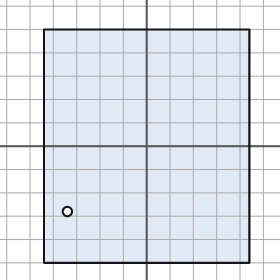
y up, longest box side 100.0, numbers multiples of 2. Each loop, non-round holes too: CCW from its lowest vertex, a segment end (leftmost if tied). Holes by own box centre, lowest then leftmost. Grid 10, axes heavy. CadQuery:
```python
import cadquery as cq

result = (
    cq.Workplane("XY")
    .moveTo(-44.0, -50.0)
    .lineTo(44.0, -50.0)
    .lineTo(44.0, 50.0)
    .lineTo(-44.0, 50.0)
    .close()
    .moveTo(-34.0, -28.0)
    .circle(2.0)
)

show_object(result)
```